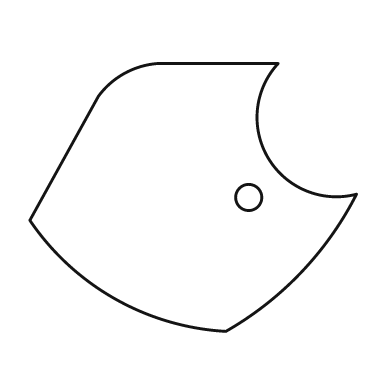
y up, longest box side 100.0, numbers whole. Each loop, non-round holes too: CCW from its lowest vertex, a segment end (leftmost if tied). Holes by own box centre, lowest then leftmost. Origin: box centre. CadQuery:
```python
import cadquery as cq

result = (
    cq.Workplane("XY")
    .moveTo(10.0, -41.0)
    .threePointArc((33.0, -23.0), (50.0, 1.0))
    .threePointArc((23.0, 12.0), (26.0, 41.0))
    .lineTo(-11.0, 41.0)
    .threePointArc((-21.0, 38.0), (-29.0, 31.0))
    .lineTo(-50.0, -7.0)
    .threePointArc((-24.0, -31.0), (10.0, -41.0))
    .close()
    .moveTo(17.0, 0.0)
    .circle(4.0)
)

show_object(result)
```